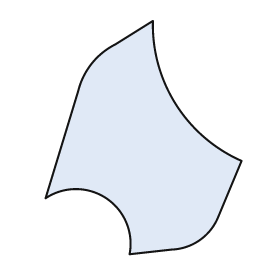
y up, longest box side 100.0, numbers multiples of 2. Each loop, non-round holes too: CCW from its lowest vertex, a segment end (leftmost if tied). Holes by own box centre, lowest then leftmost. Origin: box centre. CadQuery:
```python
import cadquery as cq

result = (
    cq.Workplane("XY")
    .moveTo(-6.0, -50.0)
    .lineTo(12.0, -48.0)
    .threePointArc((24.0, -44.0), (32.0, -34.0))
    .lineTo(42.0, -10.0)
    .threePointArc((14.0, 14.0), (4.0, 50.0))
    .lineTo(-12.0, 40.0)
    .threePointArc((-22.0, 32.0), (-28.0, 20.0))
    .lineTo(-42.0, -26.0)
    .threePointArc((-16.0, -26.0), (-6.0, -50.0))
    .close()
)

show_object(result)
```